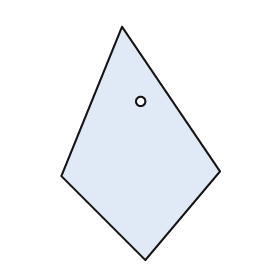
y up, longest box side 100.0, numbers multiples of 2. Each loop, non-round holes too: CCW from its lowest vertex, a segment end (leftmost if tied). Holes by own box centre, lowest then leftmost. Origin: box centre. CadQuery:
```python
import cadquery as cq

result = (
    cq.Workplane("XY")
    .moveTo(2.0, -50.0)
    .lineTo(34.0, -12.0)
    .lineTo(-8.0, 50.0)
    .lineTo(-34.0, -14.0)
    .close()
    .moveTo(0.0, 18.0)
    .circle(2.0)
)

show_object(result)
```